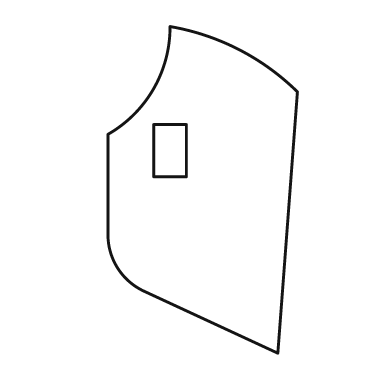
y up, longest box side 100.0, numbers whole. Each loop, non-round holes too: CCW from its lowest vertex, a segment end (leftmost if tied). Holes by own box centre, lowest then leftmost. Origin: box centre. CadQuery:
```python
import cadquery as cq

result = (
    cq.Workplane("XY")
    .moveTo(23.0, -50.0)
    .lineTo(29.0, 30.0)
    .threePointArc((11.0, 43.0), (-10.0, 50.0))
    .threePointArc((-15.0, 31.0), (-29.0, 17.0))
    .lineTo(-29.0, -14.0)
    .threePointArc((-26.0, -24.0), (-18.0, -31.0))
    .close()
    .moveTo(-15.0, 4.0)
    .lineTo(-5.0, 4.0)
    .lineTo(-5.0, 20.0)
    .lineTo(-15.0, 20.0)
    .close()
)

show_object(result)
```